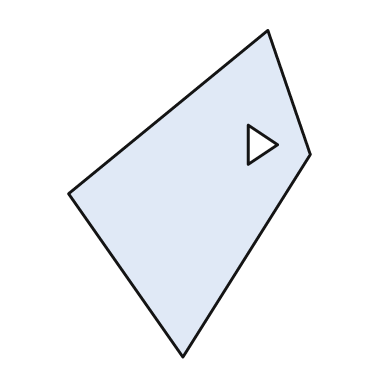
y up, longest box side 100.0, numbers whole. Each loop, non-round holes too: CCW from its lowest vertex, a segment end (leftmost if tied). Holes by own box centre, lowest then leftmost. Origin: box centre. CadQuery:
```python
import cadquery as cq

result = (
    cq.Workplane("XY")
    .moveTo(-2.0, -50.0)
    .lineTo(37.0, 12.0)
    .lineTo(24.0, 50.0)
    .lineTo(-37.0, 0.0)
    .close()
    .moveTo(18.0, 9.0)
    .lineTo(27.0, 15.0)
    .lineTo(18.0, 21.0)
    .close()
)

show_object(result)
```